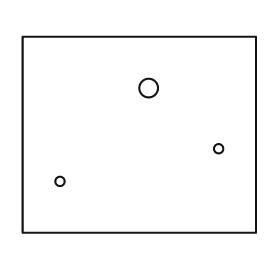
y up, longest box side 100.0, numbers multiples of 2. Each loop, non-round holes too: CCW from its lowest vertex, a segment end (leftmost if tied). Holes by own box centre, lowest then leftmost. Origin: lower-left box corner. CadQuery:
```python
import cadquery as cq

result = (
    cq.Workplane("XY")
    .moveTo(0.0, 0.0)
    .lineTo(100.0, 0.0)
    .lineTo(100.0, 84.0)
    .lineTo(0.0, 84.0)
    .close()
    .moveTo(16.0, 22.0)
    .circle(2.0)
    .moveTo(84.0, 36.0)
    .circle(2.0)
    .moveTo(54.0, 62.0)
    .circle(4.0)
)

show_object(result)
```